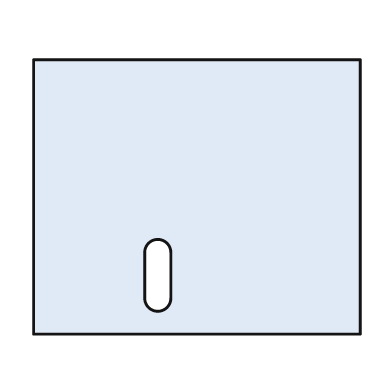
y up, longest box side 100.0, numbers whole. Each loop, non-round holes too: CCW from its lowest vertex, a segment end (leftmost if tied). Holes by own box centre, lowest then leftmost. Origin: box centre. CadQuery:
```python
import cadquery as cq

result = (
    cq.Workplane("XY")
    .moveTo(-50.0, -42.0)
    .lineTo(50.0, -42.0)
    .lineTo(50.0, 42.0)
    .lineTo(-50.0, 42.0)
    .close()
    .moveTo(-16.0, -31.0)
    .threePointArc((-12.0, -35.0), (-8.0, -31.0))
    .lineTo(-8.0, -17.0)
    .threePointArc((-12.0, -13.0), (-16.0, -17.0))
    .close()
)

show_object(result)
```